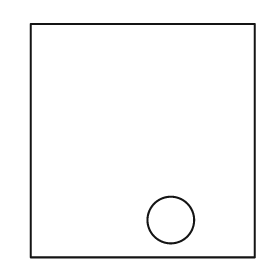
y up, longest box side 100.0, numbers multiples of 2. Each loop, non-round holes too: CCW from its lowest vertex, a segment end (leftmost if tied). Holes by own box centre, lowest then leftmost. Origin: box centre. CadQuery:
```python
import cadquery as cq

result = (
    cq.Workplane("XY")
    .moveTo(-48.0, -50.0)
    .lineTo(48.0, -50.0)
    .lineTo(48.0, 50.0)
    .lineTo(-48.0, 50.0)
    .close()
    .moveTo(12.0, -34.0)
    .circle(10.0)
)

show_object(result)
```